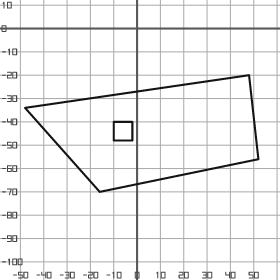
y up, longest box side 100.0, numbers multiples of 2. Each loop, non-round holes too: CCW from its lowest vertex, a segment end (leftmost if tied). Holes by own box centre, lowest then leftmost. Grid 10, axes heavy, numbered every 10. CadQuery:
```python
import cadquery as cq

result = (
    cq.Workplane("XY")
    .moveTo(-16.0, -70.0)
    .lineTo(52.0, -56.0)
    .lineTo(48.0, -20.0)
    .lineTo(-48.0, -34.0)
    .close()
    .moveTo(-10.0, -48.0)
    .lineTo(-2.0, -48.0)
    .lineTo(-2.0, -40.0)
    .lineTo(-10.0, -40.0)
    .close()
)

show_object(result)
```